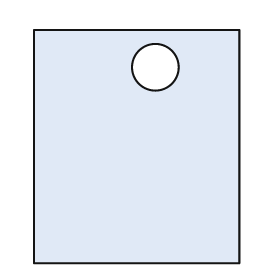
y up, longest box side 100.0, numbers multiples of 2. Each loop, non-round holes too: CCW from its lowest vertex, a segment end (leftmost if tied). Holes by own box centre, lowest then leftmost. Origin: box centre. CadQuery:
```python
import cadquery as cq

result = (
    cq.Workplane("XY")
    .moveTo(-44.0, -50.0)
    .lineTo(44.0, -50.0)
    .lineTo(44.0, 50.0)
    .lineTo(-44.0, 50.0)
    .close()
    .moveTo(8.0, 34.0)
    .circle(10.0)
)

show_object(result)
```